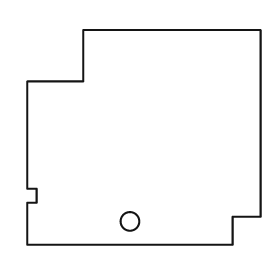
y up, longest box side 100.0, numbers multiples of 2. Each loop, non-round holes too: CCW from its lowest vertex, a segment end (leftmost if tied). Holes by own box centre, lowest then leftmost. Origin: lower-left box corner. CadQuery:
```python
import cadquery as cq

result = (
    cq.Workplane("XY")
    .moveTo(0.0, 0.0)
    .lineTo(88.0, 0.0)
    .lineTo(88.0, 12.0)
    .lineTo(100.0, 12.0)
    .lineTo(100.0, 92.0)
    .lineTo(24.0, 92.0)
    .lineTo(24.0, 70.0)
    .lineTo(0.0, 70.0)
    .lineTo(0.0, 24.0)
    .lineTo(4.0, 24.0)
    .lineTo(4.0, 18.0)
    .lineTo(0.0, 18.0)
    .close()
    .moveTo(44.0, 10.0)
    .circle(4.0)
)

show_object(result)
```